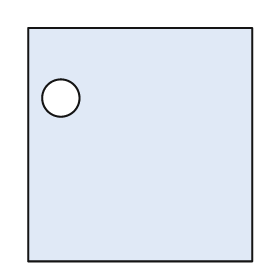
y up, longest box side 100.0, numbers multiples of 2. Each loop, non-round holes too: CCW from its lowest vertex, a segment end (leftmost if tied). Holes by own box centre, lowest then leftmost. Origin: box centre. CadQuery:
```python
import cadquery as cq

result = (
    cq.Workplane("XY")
    .moveTo(-48.0, -50.0)
    .lineTo(48.0, -50.0)
    .lineTo(48.0, 50.0)
    .lineTo(-48.0, 50.0)
    .close()
    .moveTo(-34.0, 20.0)
    .circle(8.0)
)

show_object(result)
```